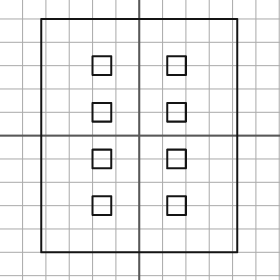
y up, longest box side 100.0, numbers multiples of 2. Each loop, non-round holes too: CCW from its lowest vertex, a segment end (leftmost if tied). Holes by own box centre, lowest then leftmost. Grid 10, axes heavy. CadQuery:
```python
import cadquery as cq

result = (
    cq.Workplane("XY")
    .moveTo(-42.0, -50.0)
    .lineTo(42.0, -50.0)
    .lineTo(42.0, 50.0)
    .lineTo(-42.0, 50.0)
    .close()
    .moveTo(-20.0, -34.0)
    .lineTo(-12.0, -34.0)
    .lineTo(-12.0, -26.0)
    .lineTo(-20.0, -26.0)
    .close()
    .moveTo(12.0, -34.0)
    .lineTo(20.0, -34.0)
    .lineTo(20.0, -26.0)
    .lineTo(12.0, -26.0)
    .close()
    .moveTo(-20.0, -14.0)
    .lineTo(-12.0, -14.0)
    .lineTo(-12.0, -6.0)
    .lineTo(-20.0, -6.0)
    .close()
    .moveTo(12.0, -14.0)
    .lineTo(20.0, -14.0)
    .lineTo(20.0, -6.0)
    .lineTo(12.0, -6.0)
    .close()
    .moveTo(-20.0, 6.0)
    .lineTo(-12.0, 6.0)
    .lineTo(-12.0, 14.0)
    .lineTo(-20.0, 14.0)
    .close()
    .moveTo(12.0, 6.0)
    .lineTo(20.0, 6.0)
    .lineTo(20.0, 14.0)
    .lineTo(12.0, 14.0)
    .close()
    .moveTo(-20.0, 26.0)
    .lineTo(-12.0, 26.0)
    .lineTo(-12.0, 34.0)
    .lineTo(-20.0, 34.0)
    .close()
    .moveTo(12.0, 26.0)
    .lineTo(20.0, 26.0)
    .lineTo(20.0, 34.0)
    .lineTo(12.0, 34.0)
    .close()
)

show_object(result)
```